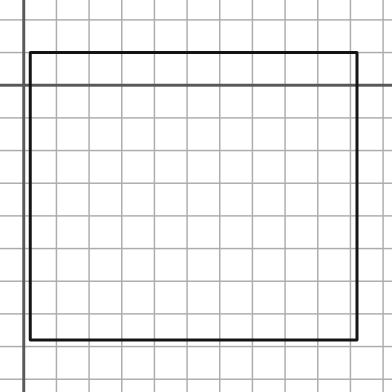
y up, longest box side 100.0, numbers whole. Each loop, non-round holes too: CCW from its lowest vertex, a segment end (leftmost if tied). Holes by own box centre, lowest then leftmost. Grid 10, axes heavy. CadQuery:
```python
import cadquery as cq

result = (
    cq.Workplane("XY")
    .moveTo(2.0, -78.0)
    .lineTo(102.0, -78.0)
    .lineTo(102.0, 10.0)
    .lineTo(2.0, 10.0)
    .close()
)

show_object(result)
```